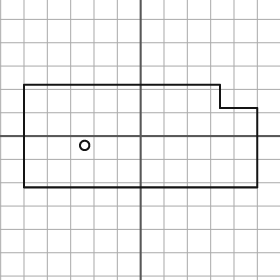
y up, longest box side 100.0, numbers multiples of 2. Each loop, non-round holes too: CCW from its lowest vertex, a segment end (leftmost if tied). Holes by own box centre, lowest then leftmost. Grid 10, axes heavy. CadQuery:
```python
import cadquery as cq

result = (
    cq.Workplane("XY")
    .moveTo(-50.0, -22.0)
    .lineTo(50.0, -22.0)
    .lineTo(50.0, 12.0)
    .lineTo(34.0, 12.0)
    .lineTo(34.0, 22.0)
    .lineTo(-50.0, 22.0)
    .close()
    .moveTo(-24.0, -4.0)
    .circle(2.0)
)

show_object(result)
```